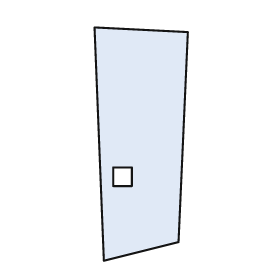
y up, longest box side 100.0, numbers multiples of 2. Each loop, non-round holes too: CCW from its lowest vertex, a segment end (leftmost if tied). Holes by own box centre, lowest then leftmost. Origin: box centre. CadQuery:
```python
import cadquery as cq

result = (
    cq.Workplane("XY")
    .moveTo(-16.0, -50.0)
    .lineTo(16.0, -42.0)
    .lineTo(20.0, 48.0)
    .lineTo(-20.0, 50.0)
    .close()
    .moveTo(-12.0, -18.0)
    .lineTo(-4.0, -18.0)
    .lineTo(-4.0, -10.0)
    .lineTo(-12.0, -10.0)
    .close()
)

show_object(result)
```